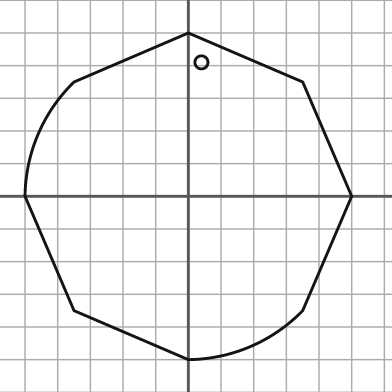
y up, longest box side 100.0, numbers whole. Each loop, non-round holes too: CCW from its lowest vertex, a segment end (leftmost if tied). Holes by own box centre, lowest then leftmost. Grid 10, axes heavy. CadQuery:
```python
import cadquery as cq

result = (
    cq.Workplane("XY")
    .moveTo(0.0, -50.0)
    .threePointArc((19.0, -46.0), (35.0, -35.0))
    .lineTo(50.0, 0.0)
    .lineTo(35.0, 35.0)
    .lineTo(0.0, 50.0)
    .lineTo(-35.0, 35.0)
    .threePointArc((-46.0, 19.0), (-50.0, 0.0))
    .lineTo(-35.0, -35.0)
    .close()
    .moveTo(4.0, 41.0)
    .circle(2.0)
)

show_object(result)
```